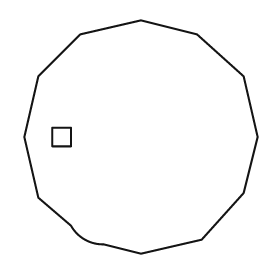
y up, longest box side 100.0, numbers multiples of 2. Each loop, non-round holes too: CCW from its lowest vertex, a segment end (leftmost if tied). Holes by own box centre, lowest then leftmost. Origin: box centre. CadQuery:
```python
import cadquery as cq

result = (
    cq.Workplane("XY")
    .moveTo(0.0, -50.0)
    .lineTo(26.0, -44.0)
    .lineTo(44.0, -24.0)
    .lineTo(50.0, 0.0)
    .lineTo(44.0, 26.0)
    .lineTo(24.0, 44.0)
    .lineTo(0.0, 50.0)
    .lineTo(-26.0, 44.0)
    .lineTo(-44.0, 26.0)
    .lineTo(-50.0, 0.0)
    .lineTo(-44.0, -26.0)
    .lineTo(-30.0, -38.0)
    .threePointArc((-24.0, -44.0), (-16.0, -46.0))
    .close()
    .moveTo(-38.0, -4.0)
    .lineTo(-30.0, -4.0)
    .lineTo(-30.0, 4.0)
    .lineTo(-38.0, 4.0)
    .close()
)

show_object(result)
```